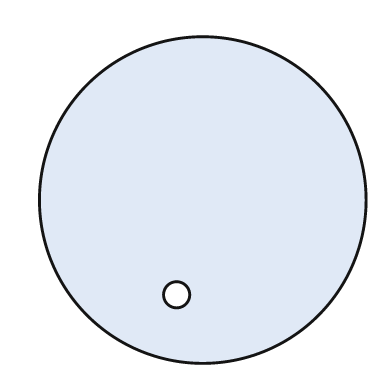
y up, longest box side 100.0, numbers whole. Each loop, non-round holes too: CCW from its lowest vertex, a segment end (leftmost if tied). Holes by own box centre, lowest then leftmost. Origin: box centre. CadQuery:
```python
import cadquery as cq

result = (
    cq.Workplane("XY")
    .moveTo(0.0, 0.0)
    .circle(50.0)
    .moveTo(-8.0, -29.0)
    .circle(4.0)
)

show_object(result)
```